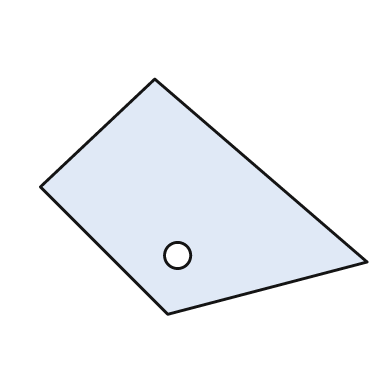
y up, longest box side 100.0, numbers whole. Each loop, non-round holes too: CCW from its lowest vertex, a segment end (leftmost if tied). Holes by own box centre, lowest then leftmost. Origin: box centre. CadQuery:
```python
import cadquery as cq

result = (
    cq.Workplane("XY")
    .moveTo(-11.0, -36.0)
    .lineTo(50.0, -20.0)
    .lineTo(-15.0, 36.0)
    .lineTo(-50.0, 3.0)
    .close()
    .moveTo(-8.0, -18.0)
    .circle(4.0)
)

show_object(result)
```